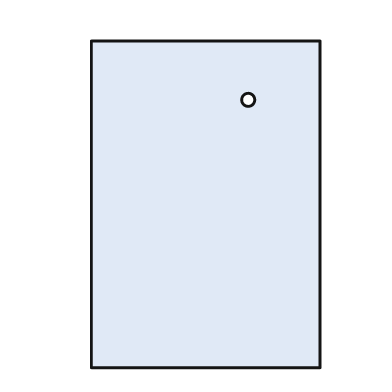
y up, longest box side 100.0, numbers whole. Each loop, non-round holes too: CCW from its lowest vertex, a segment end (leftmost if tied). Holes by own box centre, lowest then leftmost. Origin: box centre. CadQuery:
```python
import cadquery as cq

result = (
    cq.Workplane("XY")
    .moveTo(-35.0, -50.0)
    .lineTo(35.0, -50.0)
    .lineTo(35.0, 50.0)
    .lineTo(-35.0, 50.0)
    .close()
    .moveTo(13.0, 32.0)
    .circle(2.0)
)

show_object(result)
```